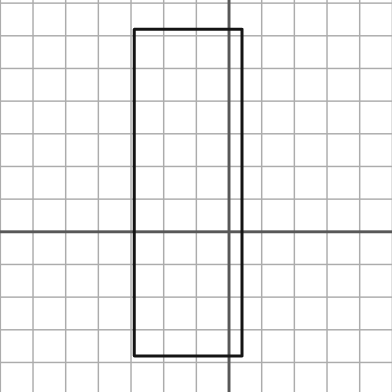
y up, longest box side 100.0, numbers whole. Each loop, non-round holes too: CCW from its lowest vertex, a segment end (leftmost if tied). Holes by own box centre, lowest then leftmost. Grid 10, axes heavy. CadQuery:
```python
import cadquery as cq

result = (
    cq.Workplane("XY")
    .moveTo(-29.0, -38.0)
    .lineTo(4.0, -38.0)
    .lineTo(4.0, 62.0)
    .lineTo(-29.0, 62.0)
    .close()
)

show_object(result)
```